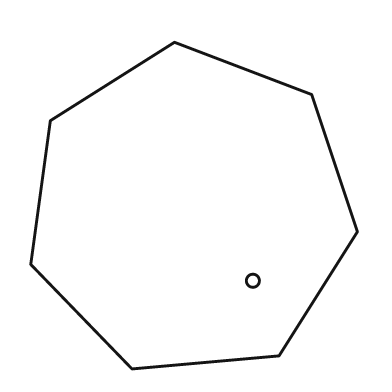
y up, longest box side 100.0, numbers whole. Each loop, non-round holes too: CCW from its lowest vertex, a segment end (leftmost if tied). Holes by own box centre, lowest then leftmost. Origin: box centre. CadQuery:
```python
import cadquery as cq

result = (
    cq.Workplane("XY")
    .moveTo(-19.0, -50.0)
    .lineTo(26.0, -46.0)
    .lineTo(50.0, -8.0)
    .lineTo(36.0, 34.0)
    .lineTo(-6.0, 50.0)
    .lineTo(-44.0, 26.0)
    .lineTo(-50.0, -18.0)
    .close()
    .moveTo(18.0, -23.0)
    .circle(2.0)
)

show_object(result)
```